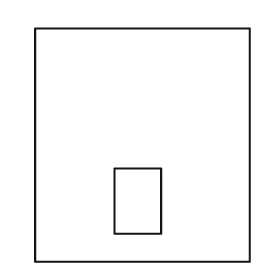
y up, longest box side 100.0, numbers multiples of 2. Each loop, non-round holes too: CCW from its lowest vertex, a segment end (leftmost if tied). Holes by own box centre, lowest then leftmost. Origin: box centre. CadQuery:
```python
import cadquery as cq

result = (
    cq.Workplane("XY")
    .moveTo(-46.0, -50.0)
    .lineTo(46.0, -50.0)
    .lineTo(46.0, 50.0)
    .lineTo(-46.0, 50.0)
    .close()
    .moveTo(-12.0, -38.0)
    .lineTo(8.0, -38.0)
    .lineTo(8.0, -10.0)
    .lineTo(-12.0, -10.0)
    .close()
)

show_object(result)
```